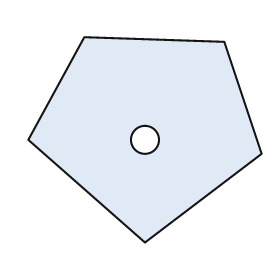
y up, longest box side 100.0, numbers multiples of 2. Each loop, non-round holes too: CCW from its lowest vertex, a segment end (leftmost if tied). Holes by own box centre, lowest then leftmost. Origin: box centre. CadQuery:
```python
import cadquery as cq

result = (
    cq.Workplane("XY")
    .moveTo(0.0, -44.0)
    .lineTo(50.0, -6.0)
    .lineTo(34.0, 42.0)
    .lineTo(-26.0, 44.0)
    .lineTo(-50.0, 0.0)
    .close()
    .moveTo(0.0, 0.0)
    .circle(6.0)
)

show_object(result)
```